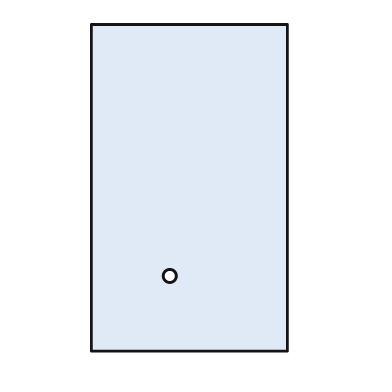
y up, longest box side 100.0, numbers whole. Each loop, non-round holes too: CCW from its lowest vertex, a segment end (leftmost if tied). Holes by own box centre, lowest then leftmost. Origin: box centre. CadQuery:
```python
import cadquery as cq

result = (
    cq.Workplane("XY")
    .moveTo(-30.0, -50.0)
    .lineTo(30.0, -50.0)
    .lineTo(30.0, 50.0)
    .lineTo(-30.0, 50.0)
    .close()
    .moveTo(-6.0, -27.0)
    .circle(2.0)
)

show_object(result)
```